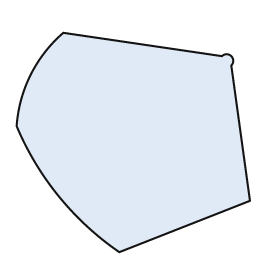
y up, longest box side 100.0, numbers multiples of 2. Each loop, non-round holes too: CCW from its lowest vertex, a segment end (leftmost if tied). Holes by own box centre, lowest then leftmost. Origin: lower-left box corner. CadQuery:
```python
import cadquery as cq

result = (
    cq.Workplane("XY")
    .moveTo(44.0, 0.0)
    .lineTo(100.0, 22.0)
    .lineTo(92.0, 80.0)
    .threePointArc((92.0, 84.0), (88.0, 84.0))
    .lineTo(20.0, 94.0)
    .threePointArc((6.0, 76.0), (0.0, 54.0))
    .threePointArc((18.0, 24.0), (44.0, 0.0))
    .close()
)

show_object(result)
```